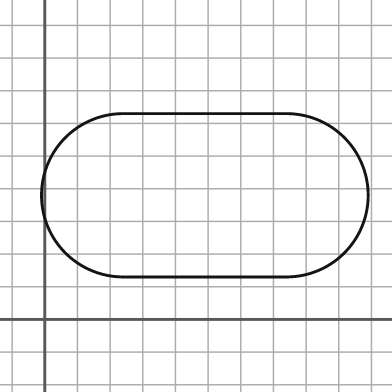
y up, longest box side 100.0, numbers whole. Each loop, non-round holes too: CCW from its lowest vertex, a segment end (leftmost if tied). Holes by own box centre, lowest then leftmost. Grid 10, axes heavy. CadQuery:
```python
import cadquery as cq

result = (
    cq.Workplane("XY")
    .moveTo(24.0, 13.0)
    .lineTo(74.0, 13.0)
    .threePointArc((99.0, 38.0), (74.0, 63.0))
    .lineTo(24.0, 63.0)
    .threePointArc((-1.0, 38.0), (24.0, 13.0))
    .close()
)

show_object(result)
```